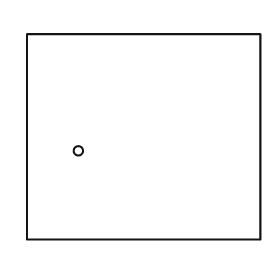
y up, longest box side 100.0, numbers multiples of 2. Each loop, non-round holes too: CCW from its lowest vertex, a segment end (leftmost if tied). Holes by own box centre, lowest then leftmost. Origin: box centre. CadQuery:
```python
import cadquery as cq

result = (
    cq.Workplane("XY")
    .moveTo(-50.0, -44.0)
    .lineTo(50.0, -44.0)
    .lineTo(50.0, 44.0)
    .lineTo(-50.0, 44.0)
    .close()
    .moveTo(-28.0, -6.0)
    .circle(2.0)
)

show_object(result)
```